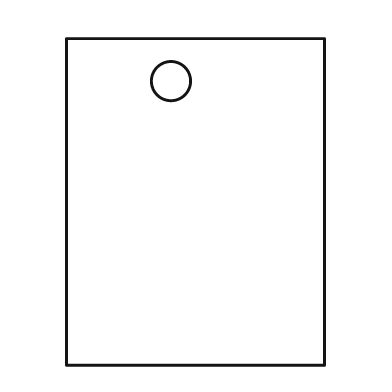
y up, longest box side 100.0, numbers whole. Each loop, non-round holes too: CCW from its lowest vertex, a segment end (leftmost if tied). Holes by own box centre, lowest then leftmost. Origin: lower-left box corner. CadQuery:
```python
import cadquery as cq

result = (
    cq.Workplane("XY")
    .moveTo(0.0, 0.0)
    .lineTo(79.0, 0.0)
    .lineTo(79.0, 100.0)
    .lineTo(0.0, 100.0)
    .close()
    .moveTo(32.0, 87.0)
    .circle(6.0)
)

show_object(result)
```